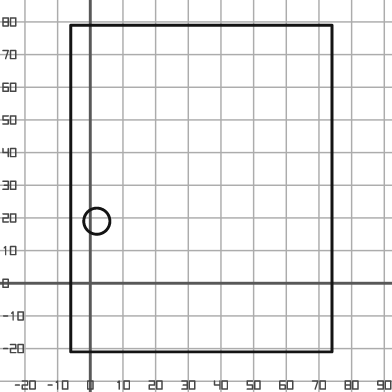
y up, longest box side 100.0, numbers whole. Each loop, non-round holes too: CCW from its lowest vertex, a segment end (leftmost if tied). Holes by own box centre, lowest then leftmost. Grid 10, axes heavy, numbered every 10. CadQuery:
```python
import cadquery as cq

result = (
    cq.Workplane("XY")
    .moveTo(-6.0, -21.0)
    .lineTo(74.0, -21.0)
    .lineTo(74.0, 79.0)
    .lineTo(-6.0, 79.0)
    .close()
    .moveTo(2.0, 19.0)
    .circle(4.0)
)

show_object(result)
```